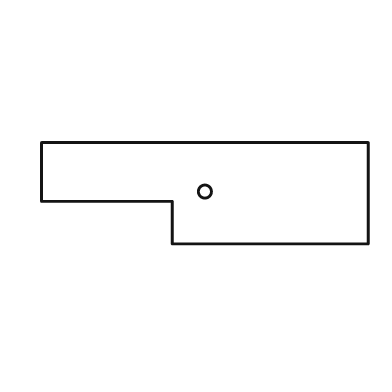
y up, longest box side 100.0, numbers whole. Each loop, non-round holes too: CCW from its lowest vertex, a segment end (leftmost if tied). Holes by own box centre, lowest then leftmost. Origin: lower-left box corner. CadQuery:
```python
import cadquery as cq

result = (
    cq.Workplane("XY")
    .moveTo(40.0, 0.0)
    .lineTo(100.0, 0.0)
    .lineTo(100.0, 31.0)
    .lineTo(0.0, 31.0)
    .lineTo(0.0, 13.0)
    .lineTo(40.0, 13.0)
    .close()
    .moveTo(50.0, 16.0)
    .circle(2.0)
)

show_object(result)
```